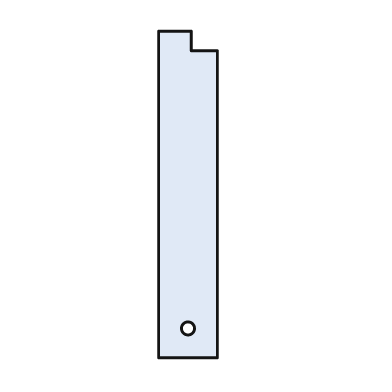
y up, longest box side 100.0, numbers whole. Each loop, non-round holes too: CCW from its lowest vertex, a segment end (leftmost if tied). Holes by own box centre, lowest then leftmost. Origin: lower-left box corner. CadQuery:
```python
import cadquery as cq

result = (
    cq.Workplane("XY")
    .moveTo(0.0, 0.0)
    .lineTo(18.0, 0.0)
    .lineTo(18.0, 94.0)
    .lineTo(10.0, 94.0)
    .lineTo(10.0, 100.0)
    .lineTo(0.0, 100.0)
    .close()
    .moveTo(9.0, 9.0)
    .circle(2.0)
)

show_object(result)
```